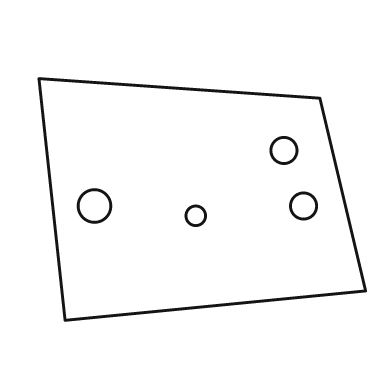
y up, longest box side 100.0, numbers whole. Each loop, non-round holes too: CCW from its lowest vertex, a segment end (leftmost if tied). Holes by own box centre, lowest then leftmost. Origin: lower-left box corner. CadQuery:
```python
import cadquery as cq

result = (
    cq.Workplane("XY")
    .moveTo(8.0, 0.0)
    .lineTo(100.0, 9.0)
    .lineTo(86.0, 68.0)
    .lineTo(0.0, 74.0)
    .close()
    .moveTo(48.0, 32.0)
    .circle(3.0)
    .moveTo(17.0, 35.0)
    .circle(5.0)
    .moveTo(81.0, 35.0)
    .circle(4.0)
    .moveTo(75.0, 52.0)
    .circle(4.0)
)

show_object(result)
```